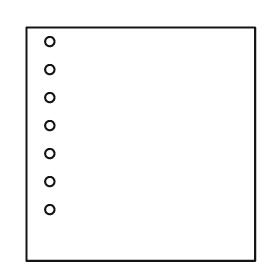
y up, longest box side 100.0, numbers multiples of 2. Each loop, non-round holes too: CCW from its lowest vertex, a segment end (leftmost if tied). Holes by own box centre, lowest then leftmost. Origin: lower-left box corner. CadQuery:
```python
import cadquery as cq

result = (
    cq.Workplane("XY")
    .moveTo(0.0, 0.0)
    .lineTo(98.0, 0.0)
    .lineTo(98.0, 100.0)
    .lineTo(0.0, 100.0)
    .close()
    .moveTo(10.0, 22.0)
    .circle(2.0)
    .moveTo(10.0, 34.0)
    .circle(2.0)
    .moveTo(10.0, 46.0)
    .circle(2.0)
    .moveTo(10.0, 58.0)
    .circle(2.0)
    .moveTo(10.0, 70.0)
    .circle(2.0)
    .moveTo(10.0, 82.0)
    .circle(2.0)
    .moveTo(10.0, 94.0)
    .circle(2.0)
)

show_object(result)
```